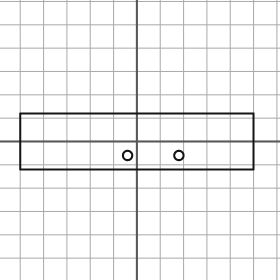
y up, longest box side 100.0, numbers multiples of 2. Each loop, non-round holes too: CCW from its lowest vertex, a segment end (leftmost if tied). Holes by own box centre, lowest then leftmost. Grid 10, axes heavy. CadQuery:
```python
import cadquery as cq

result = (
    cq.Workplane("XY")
    .moveTo(-50.0, -12.0)
    .lineTo(50.0, -12.0)
    .lineTo(50.0, 12.0)
    .lineTo(-50.0, 12.0)
    .close()
    .moveTo(-4.0, -6.0)
    .circle(2.0)
    .moveTo(18.0, -6.0)
    .circle(2.0)
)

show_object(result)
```